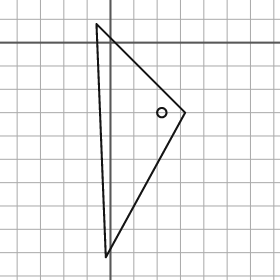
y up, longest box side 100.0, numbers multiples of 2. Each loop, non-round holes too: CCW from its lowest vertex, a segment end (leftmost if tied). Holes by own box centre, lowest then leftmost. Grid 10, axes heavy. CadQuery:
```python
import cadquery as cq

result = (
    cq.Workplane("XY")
    .moveTo(-2.0, -92.0)
    .lineTo(32.0, -30.0)
    .lineTo(-6.0, 8.0)
    .close()
    .moveTo(22.0, -30.0)
    .circle(2.0)
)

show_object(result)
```